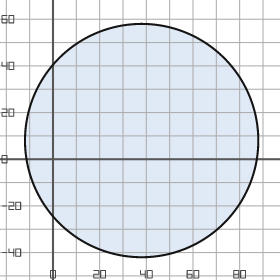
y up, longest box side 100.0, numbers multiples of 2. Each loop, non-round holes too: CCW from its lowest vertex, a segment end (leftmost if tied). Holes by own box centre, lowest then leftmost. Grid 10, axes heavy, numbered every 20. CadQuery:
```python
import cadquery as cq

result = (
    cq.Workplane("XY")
    .moveTo(38.0, 8.0)
    .circle(50.0)
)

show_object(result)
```